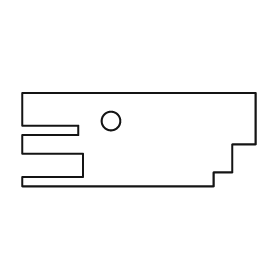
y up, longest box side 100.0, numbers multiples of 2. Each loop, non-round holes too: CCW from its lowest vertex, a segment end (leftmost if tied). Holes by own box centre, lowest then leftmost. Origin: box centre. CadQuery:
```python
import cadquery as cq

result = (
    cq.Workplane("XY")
    .moveTo(-50.0, -20.0)
    .lineTo(32.0, -20.0)
    .lineTo(32.0, -14.0)
    .lineTo(40.0, -14.0)
    .lineTo(40.0, -2.0)
    .lineTo(50.0, -2.0)
    .lineTo(50.0, 20.0)
    .lineTo(-50.0, 20.0)
    .lineTo(-50.0, 6.0)
    .lineTo(-26.0, 6.0)
    .lineTo(-26.0, 2.0)
    .lineTo(-50.0, 2.0)
    .lineTo(-50.0, -6.0)
    .lineTo(-24.0, -6.0)
    .lineTo(-24.0, -16.0)
    .lineTo(-50.0, -16.0)
    .close()
    .moveTo(-12.0, 8.0)
    .circle(4.0)
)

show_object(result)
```